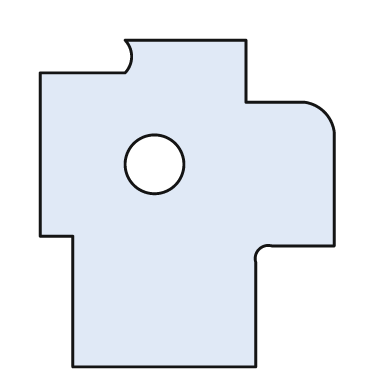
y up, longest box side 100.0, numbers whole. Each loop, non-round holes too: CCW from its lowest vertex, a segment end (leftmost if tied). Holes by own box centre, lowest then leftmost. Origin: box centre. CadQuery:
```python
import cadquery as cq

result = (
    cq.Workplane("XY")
    .moveTo(-35.0, -50.0)
    .lineTo(21.0, -50.0)
    .lineTo(21.0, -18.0)
    .threePointArc((22.0, -14.0), (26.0, -13.0))
    .lineTo(45.0, -13.0)
    .lineTo(45.0, 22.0)
    .threePointArc((42.0, 28.0), (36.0, 31.0))
    .lineTo(18.0, 31.0)
    .lineTo(18.0, 50.0)
    .lineTo(-19.0, 50.0)
    .threePointArc((-17.0, 45.0), (-19.0, 40.0))
    .lineTo(-45.0, 40.0)
    .lineTo(-45.0, -10.0)
    .lineTo(-35.0, -10.0)
    .close()
    .moveTo(-10.0, 12.0)
    .circle(9.0)
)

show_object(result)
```